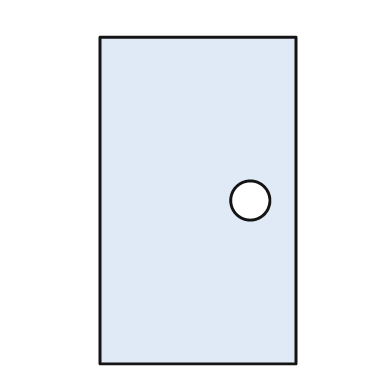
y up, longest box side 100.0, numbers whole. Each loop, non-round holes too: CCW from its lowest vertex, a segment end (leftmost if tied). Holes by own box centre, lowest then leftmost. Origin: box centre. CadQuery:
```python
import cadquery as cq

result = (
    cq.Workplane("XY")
    .moveTo(-30.0, -50.0)
    .lineTo(30.0, -50.0)
    .lineTo(30.0, 50.0)
    .lineTo(-30.0, 50.0)
    .close()
    .moveTo(16.0, 0.0)
    .circle(6.0)
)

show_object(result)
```